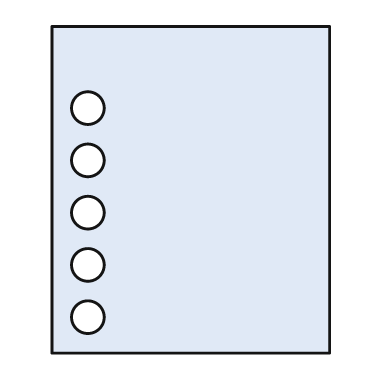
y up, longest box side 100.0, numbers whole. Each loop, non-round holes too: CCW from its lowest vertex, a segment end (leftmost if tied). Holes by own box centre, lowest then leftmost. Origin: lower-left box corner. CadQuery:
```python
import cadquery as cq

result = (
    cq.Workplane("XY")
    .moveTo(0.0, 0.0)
    .lineTo(85.0, 0.0)
    .lineTo(85.0, 100.0)
    .lineTo(0.0, 100.0)
    .close()
    .moveTo(11.0, 11.0)
    .circle(5.0)
    .moveTo(11.0, 27.0)
    .circle(5.0)
    .moveTo(11.0, 43.0)
    .circle(5.0)
    .moveTo(11.0, 59.0)
    .circle(5.0)
    .moveTo(11.0, 75.0)
    .circle(5.0)
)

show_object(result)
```